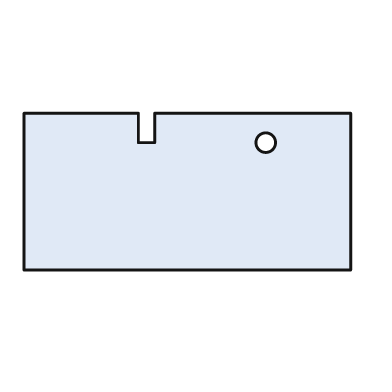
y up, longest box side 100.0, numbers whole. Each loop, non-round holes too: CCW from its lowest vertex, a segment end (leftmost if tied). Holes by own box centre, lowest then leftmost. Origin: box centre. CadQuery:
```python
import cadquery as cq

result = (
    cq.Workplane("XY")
    .moveTo(-50.0, -24.0)
    .lineTo(50.0, -24.0)
    .lineTo(50.0, 24.0)
    .lineTo(-10.0, 24.0)
    .lineTo(-10.0, 15.0)
    .lineTo(-15.0, 15.0)
    .lineTo(-15.0, 24.0)
    .lineTo(-50.0, 24.0)
    .close()
    .moveTo(24.0, 15.0)
    .circle(3.0)
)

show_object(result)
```